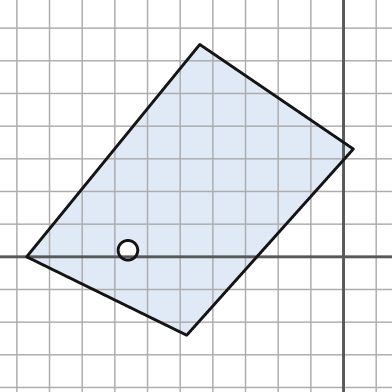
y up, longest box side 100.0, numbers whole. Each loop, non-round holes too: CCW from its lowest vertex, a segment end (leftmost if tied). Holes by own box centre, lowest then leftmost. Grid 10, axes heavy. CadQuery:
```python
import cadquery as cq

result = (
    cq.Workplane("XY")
    .moveTo(-48.0, -24.0)
    .lineTo(3.0, 33.0)
    .lineTo(-44.0, 65.0)
    .lineTo(-97.0, 0.0)
    .close()
    .moveTo(-66.0, 2.0)
    .circle(3.0)
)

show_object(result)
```